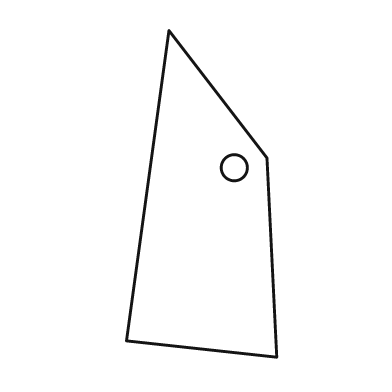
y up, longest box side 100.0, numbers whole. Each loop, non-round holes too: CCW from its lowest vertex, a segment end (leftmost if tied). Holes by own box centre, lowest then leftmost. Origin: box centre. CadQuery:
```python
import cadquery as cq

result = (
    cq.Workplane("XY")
    .moveTo(23.0, -50.0)
    .lineTo(20.0, 11.0)
    .lineTo(-10.0, 50.0)
    .lineTo(-23.0, -45.0)
    .close()
    .moveTo(10.0, 8.0)
    .circle(4.0)
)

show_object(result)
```